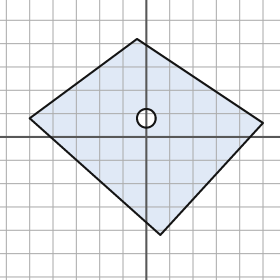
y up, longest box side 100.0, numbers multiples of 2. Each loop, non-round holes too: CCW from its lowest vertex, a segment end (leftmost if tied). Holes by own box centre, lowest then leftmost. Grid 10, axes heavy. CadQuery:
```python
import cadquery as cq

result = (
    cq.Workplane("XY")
    .moveTo(6.0, -42.0)
    .lineTo(50.0, 6.0)
    .lineTo(-4.0, 42.0)
    .lineTo(-50.0, 8.0)
    .close()
    .moveTo(0.0, 8.0)
    .circle(4.0)
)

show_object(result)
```